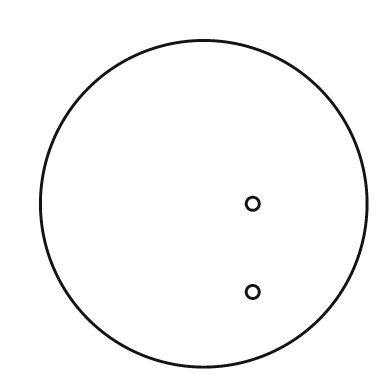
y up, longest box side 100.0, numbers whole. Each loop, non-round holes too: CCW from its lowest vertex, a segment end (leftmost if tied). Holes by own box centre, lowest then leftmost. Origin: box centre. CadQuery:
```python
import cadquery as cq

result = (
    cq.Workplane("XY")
    .moveTo(0.0, 0.0)
    .circle(50.0)
    .moveTo(15.0, -27.0)
    .circle(2.0)
    .moveTo(15.0, 0.0)
    .circle(2.0)
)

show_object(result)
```